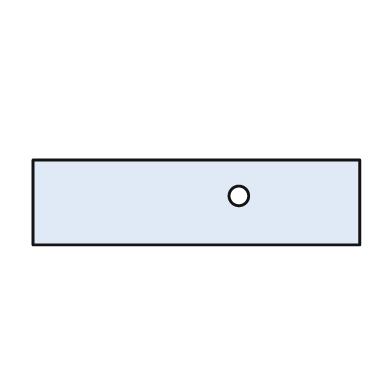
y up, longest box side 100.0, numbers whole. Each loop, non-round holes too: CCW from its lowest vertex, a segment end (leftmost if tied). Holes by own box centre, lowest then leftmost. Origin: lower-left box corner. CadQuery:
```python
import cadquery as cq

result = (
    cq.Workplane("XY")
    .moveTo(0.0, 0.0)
    .lineTo(100.0, 0.0)
    .lineTo(100.0, 26.0)
    .lineTo(0.0, 26.0)
    .close()
    .moveTo(63.0, 15.0)
    .circle(3.0)
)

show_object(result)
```